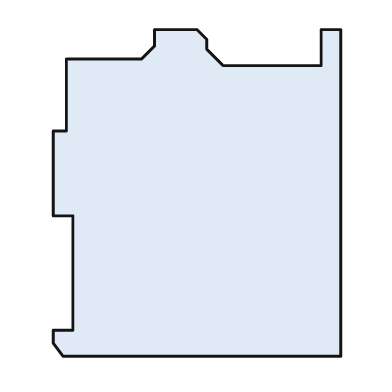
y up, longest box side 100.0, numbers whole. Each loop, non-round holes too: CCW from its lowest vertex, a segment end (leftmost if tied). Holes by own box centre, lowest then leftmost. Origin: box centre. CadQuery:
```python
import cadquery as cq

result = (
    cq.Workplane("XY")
    .moveTo(-41.0, -50.0)
    .lineTo(44.0, -50.0)
    .lineTo(44.0, 50.0)
    .lineTo(38.0, 50.0)
    .lineTo(38.0, 39.0)
    .lineTo(8.0, 39.0)
    .lineTo(3.0, 44.0)
    .lineTo(3.0, 47.0)
    .lineTo(0.0, 50.0)
    .lineTo(-13.0, 50.0)
    .lineTo(-13.0, 45.0)
    .lineTo(-17.0, 41.0)
    .lineTo(-40.0, 41.0)
    .lineTo(-40.0, 19.0)
    .lineTo(-44.0, 19.0)
    .lineTo(-44.0, -7.0)
    .lineTo(-38.0, -7.0)
    .lineTo(-38.0, -42.0)
    .lineTo(-44.0, -42.0)
    .lineTo(-44.0, -46.0)
    .close()
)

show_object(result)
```